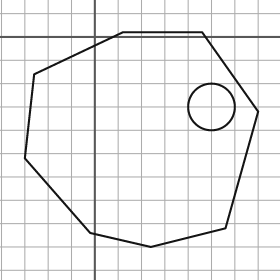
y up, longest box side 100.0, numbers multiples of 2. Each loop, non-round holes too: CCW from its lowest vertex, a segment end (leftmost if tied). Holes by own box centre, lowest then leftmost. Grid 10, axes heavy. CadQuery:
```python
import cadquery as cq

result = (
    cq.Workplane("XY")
    .moveTo(24.0, -90.0)
    .lineTo(56.0, -82.0)
    .lineTo(70.0, -32.0)
    .lineTo(46.0, 2.0)
    .lineTo(12.0, 2.0)
    .lineTo(-26.0, -16.0)
    .lineTo(-30.0, -52.0)
    .lineTo(-2.0, -84.0)
    .close()
    .moveTo(50.0, -30.0)
    .circle(10.0)
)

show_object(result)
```